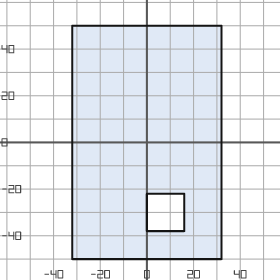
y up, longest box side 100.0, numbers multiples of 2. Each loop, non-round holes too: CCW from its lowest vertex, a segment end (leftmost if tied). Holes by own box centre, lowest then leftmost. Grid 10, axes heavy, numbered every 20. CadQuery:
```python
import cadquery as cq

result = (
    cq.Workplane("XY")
    .moveTo(-32.0, -50.0)
    .lineTo(32.0, -50.0)
    .lineTo(32.0, 50.0)
    .lineTo(-32.0, 50.0)
    .close()
    .moveTo(0.0, -38.0)
    .lineTo(16.0, -38.0)
    .lineTo(16.0, -22.0)
    .lineTo(0.0, -22.0)
    .close()
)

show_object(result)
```